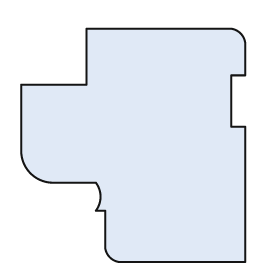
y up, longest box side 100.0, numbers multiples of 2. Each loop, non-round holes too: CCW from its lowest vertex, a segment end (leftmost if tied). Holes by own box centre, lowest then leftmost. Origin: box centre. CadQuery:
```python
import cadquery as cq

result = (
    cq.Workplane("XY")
    .moveTo(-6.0, -50.0)
    .lineTo(48.0, -50.0)
    .lineTo(48.0, 8.0)
    .lineTo(42.0, 8.0)
    .lineTo(42.0, 30.0)
    .lineTo(48.0, 30.0)
    .lineTo(48.0, 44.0)
    .threePointArc((46.0, 48.0), (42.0, 50.0))
    .lineTo(-20.0, 50.0)
    .lineTo(-20.0, 26.0)
    .lineTo(-48.0, 26.0)
    .lineTo(-48.0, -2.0)
    .threePointArc((-44.0, -12.0), (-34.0, -16.0))
    .lineTo(-16.0, -16.0)
    .threePointArc((-14.0, -22.0), (-16.0, -28.0))
    .lineTo(-12.0, -28.0)
    .lineTo(-12.0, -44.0)
    .threePointArc((-10.0, -48.0), (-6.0, -50.0))
    .close()
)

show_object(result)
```